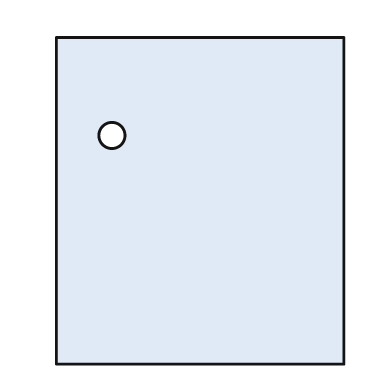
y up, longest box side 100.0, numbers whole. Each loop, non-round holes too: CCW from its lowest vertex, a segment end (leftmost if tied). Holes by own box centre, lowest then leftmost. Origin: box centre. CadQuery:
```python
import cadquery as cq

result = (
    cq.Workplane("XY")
    .moveTo(-44.0, -50.0)
    .lineTo(44.0, -50.0)
    .lineTo(44.0, 50.0)
    .lineTo(-44.0, 50.0)
    .close()
    .moveTo(-27.0, 20.0)
    .circle(4.0)
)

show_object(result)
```